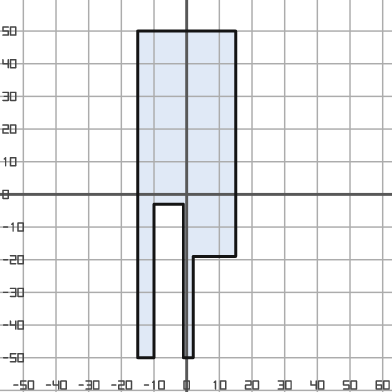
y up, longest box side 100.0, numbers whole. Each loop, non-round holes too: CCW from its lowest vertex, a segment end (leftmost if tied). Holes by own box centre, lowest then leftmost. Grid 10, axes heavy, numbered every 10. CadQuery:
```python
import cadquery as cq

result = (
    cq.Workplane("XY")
    .moveTo(-15.0, -50.0)
    .lineTo(-10.0, -50.0)
    .lineTo(-10.0, -3.0)
    .lineTo(-1.0, -3.0)
    .lineTo(-1.0, -50.0)
    .lineTo(2.0, -50.0)
    .lineTo(2.0, -19.0)
    .lineTo(15.0, -19.0)
    .lineTo(15.0, 50.0)
    .lineTo(-15.0, 50.0)
    .close()
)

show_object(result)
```